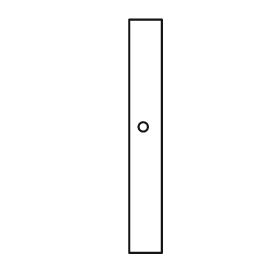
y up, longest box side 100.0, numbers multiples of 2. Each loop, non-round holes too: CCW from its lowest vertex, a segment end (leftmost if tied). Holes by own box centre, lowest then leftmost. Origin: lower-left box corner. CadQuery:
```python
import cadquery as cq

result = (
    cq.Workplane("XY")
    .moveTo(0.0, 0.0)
    .lineTo(14.0, 0.0)
    .lineTo(14.0, 100.0)
    .lineTo(0.0, 100.0)
    .close()
    .moveTo(6.0, 54.0)
    .circle(2.0)
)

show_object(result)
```